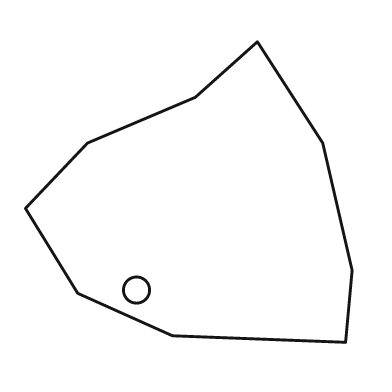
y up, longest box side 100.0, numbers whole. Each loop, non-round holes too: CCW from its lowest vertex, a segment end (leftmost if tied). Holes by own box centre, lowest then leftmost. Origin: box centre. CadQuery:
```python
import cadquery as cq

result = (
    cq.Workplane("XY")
    .moveTo(48.0, -46.0)
    .lineTo(50.0, -24.0)
    .lineTo(41.0, 15.0)
    .lineTo(21.0, 46.0)
    .lineTo(2.0, 29.0)
    .lineTo(-31.0, 15.0)
    .lineTo(-50.0, -5.0)
    .lineTo(-34.0, -31.0)
    .lineTo(-5.0, -44.0)
    .close()
    .moveTo(-16.0, -30.0)
    .circle(4.0)
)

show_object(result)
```